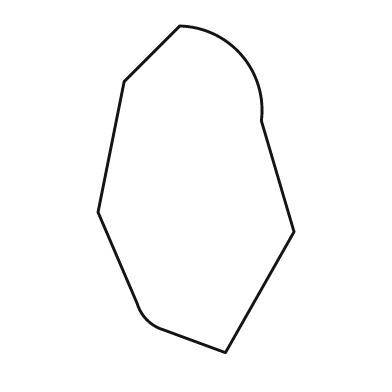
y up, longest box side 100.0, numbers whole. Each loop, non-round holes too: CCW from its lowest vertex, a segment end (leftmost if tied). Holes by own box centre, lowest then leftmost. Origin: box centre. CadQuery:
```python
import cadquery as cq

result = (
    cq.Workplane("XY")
    .moveTo(9.0, -50.0)
    .lineTo(30.0, -13.0)
    .lineTo(20.0, 21.0)
    .threePointArc((14.0, 41.0), (-5.0, 50.0))
    .lineTo(-22.0, 33.0)
    .lineTo(-30.0, -7.0)
    .lineTo(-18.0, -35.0)
    .threePointArc((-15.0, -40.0), (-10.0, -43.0))
    .close()
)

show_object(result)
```